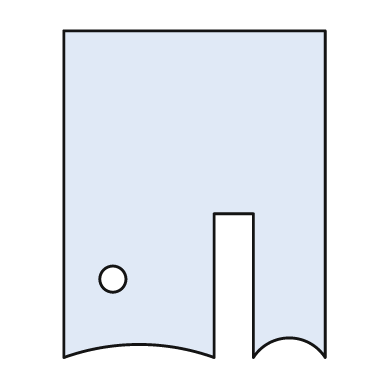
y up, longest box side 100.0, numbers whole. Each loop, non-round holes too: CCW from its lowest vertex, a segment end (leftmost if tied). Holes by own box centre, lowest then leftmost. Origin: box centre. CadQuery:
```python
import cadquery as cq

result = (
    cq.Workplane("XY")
    .moveTo(-40.0, -50.0)
    .threePointArc((-17.0, -46.0), (6.0, -50.0))
    .lineTo(6.0, -6.0)
    .lineTo(18.0, -6.0)
    .lineTo(18.0, -50.0)
    .threePointArc((29.0, -44.0), (40.0, -50.0))
    .lineTo(40.0, 50.0)
    .lineTo(-40.0, 50.0)
    .close()
    .moveTo(-25.0, -26.0)
    .circle(4.0)
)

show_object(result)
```